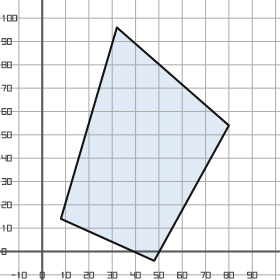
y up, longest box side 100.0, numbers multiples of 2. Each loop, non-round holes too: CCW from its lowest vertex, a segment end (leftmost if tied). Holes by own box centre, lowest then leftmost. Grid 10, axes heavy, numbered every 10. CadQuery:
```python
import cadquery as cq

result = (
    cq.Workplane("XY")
    .moveTo(48.0, -4.0)
    .lineTo(80.0, 54.0)
    .lineTo(32.0, 96.0)
    .lineTo(8.0, 14.0)
    .close()
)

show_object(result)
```